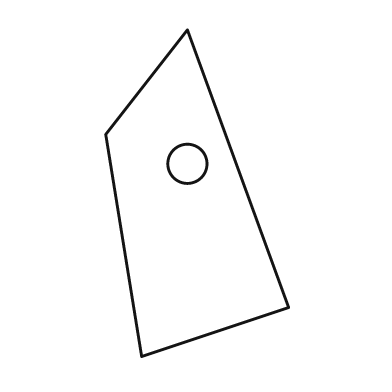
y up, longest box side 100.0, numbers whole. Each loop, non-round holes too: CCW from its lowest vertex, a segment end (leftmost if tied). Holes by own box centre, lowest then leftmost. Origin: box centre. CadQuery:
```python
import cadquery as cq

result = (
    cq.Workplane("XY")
    .moveTo(-17.0, -50.0)
    .lineTo(28.0, -35.0)
    .lineTo(-3.0, 50.0)
    .lineTo(-28.0, 18.0)
    .close()
    .moveTo(-3.0, 9.0)
    .circle(6.0)
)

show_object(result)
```